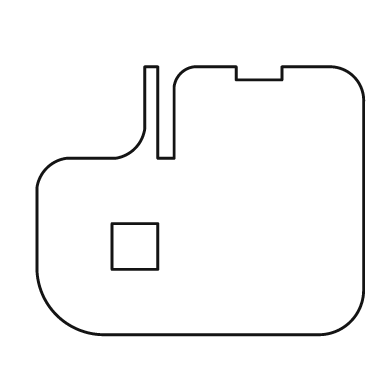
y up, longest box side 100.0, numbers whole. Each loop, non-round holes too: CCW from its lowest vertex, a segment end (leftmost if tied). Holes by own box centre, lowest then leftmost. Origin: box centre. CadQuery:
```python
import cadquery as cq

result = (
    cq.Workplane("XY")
    .moveTo(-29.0, -41.0)
    .lineTo(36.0, -41.0)
    .threePointArc((46.0, -37.0), (50.0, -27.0))
    .lineTo(50.0, 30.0)
    .threePointArc((47.0, 38.0), (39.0, 41.0))
    .lineTo(25.0, 41.0)
    .lineTo(25.0, 37.0)
    .lineTo(11.0, 37.0)
    .lineTo(11.0, 41.0)
    .lineTo(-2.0, 41.0)
    .threePointArc((-6.0, 39.0), (-8.0, 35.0))
    .lineTo(-8.0, 13.0)
    .lineTo(-13.0, 13.0)
    .lineTo(-13.0, 41.0)
    .lineTo(-17.0, 41.0)
    .lineTo(-17.0, 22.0)
    .threePointArc((-20.0, 16.0), (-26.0, 13.0))
    .lineTo(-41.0, 13.0)
    .threePointArc((-47.0, 10.0), (-50.0, 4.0))
    .lineTo(-50.0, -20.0)
    .threePointArc((-44.0, -35.0), (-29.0, -41.0))
    .close()
    .moveTo(-27.0, -21.0)
    .lineTo(-13.0, -21.0)
    .lineTo(-13.0, -7.0)
    .lineTo(-27.0, -7.0)
    .close()
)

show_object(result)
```